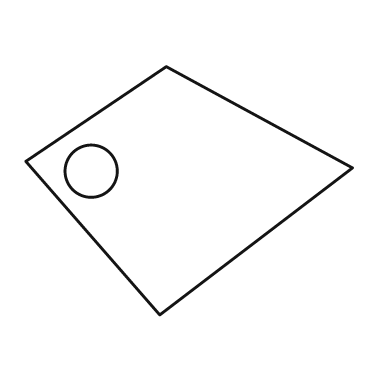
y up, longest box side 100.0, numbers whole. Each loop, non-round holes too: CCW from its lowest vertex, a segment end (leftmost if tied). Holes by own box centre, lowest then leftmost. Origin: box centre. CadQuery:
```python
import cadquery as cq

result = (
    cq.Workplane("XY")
    .moveTo(-9.0, -38.0)
    .lineTo(50.0, 7.0)
    .lineTo(-7.0, 38.0)
    .lineTo(-50.0, 9.0)
    .close()
    .moveTo(-30.0, 6.0)
    .circle(8.0)
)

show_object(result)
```